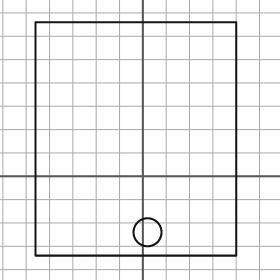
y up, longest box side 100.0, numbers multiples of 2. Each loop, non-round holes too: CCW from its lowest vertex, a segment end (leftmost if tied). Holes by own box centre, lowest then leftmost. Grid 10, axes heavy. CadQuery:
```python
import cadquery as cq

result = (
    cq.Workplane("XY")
    .moveTo(-46.0, -34.0)
    .lineTo(40.0, -34.0)
    .lineTo(40.0, 66.0)
    .lineTo(-46.0, 66.0)
    .close()
    .moveTo(2.0, -24.0)
    .circle(6.0)
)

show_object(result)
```